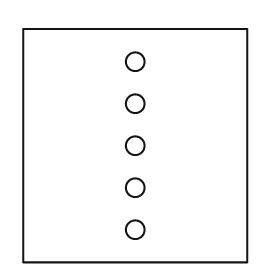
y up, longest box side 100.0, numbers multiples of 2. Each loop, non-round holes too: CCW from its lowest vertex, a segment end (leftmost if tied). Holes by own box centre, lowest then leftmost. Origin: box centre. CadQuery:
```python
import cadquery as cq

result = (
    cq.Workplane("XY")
    .moveTo(-48.0, -50.0)
    .lineTo(48.0, -50.0)
    .lineTo(48.0, 50.0)
    .lineTo(-48.0, 50.0)
    .close()
    .moveTo(0.0, -36.0)
    .circle(4.0)
    .moveTo(0.0, -18.0)
    .circle(4.0)
    .moveTo(0.0, 0.0)
    .circle(4.0)
    .moveTo(0.0, 18.0)
    .circle(4.0)
    .moveTo(0.0, 36.0)
    .circle(4.0)
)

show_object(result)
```